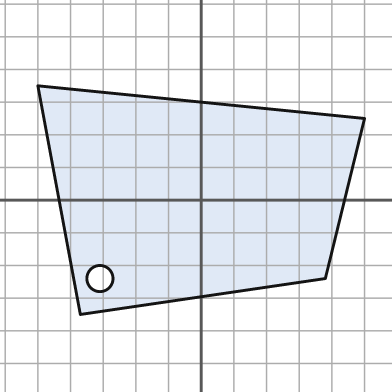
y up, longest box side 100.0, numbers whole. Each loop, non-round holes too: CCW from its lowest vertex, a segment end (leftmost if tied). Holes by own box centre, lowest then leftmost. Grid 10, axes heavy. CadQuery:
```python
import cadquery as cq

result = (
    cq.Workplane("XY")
    .moveTo(-37.0, -35.0)
    .lineTo(38.0, -24.0)
    .lineTo(50.0, 25.0)
    .lineTo(-50.0, 35.0)
    .close()
    .moveTo(-31.0, -24.0)
    .circle(4.0)
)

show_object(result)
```